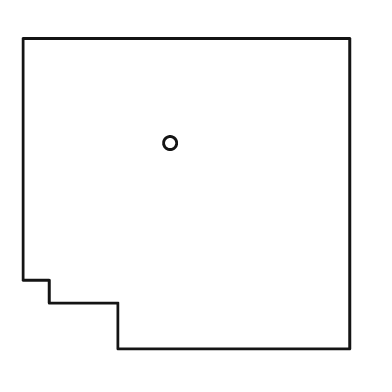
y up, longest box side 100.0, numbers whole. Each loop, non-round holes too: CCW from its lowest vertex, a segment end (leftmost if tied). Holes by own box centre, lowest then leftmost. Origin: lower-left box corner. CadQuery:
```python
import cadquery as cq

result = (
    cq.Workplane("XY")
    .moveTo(29.0, 0.0)
    .lineTo(100.0, 0.0)
    .lineTo(100.0, 95.0)
    .lineTo(0.0, 95.0)
    .lineTo(0.0, 21.0)
    .lineTo(8.0, 21.0)
    .lineTo(8.0, 14.0)
    .lineTo(29.0, 14.0)
    .close()
    .moveTo(45.0, 63.0)
    .circle(2.0)
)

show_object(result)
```